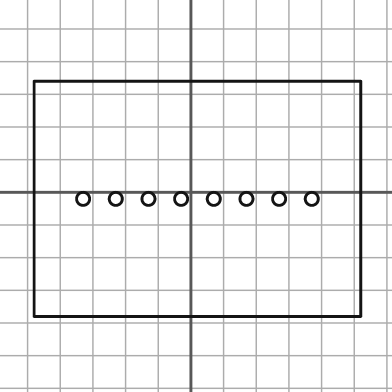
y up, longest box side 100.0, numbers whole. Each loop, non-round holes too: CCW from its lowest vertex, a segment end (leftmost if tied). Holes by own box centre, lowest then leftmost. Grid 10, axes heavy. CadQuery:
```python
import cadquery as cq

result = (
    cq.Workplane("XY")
    .moveTo(-48.0, -38.0)
    .lineTo(52.0, -38.0)
    .lineTo(52.0, 34.0)
    .lineTo(-48.0, 34.0)
    .close()
    .moveTo(-33.0, -2.0)
    .circle(2.0)
    .moveTo(-23.0, -2.0)
    .circle(2.0)
    .moveTo(-13.0, -2.0)
    .circle(2.0)
    .moveTo(-3.0, -2.0)
    .circle(2.0)
    .moveTo(7.0, -2.0)
    .circle(2.0)
    .moveTo(17.0, -2.0)
    .circle(2.0)
    .moveTo(27.0, -2.0)
    .circle(2.0)
    .moveTo(37.0, -2.0)
    .circle(2.0)
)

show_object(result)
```